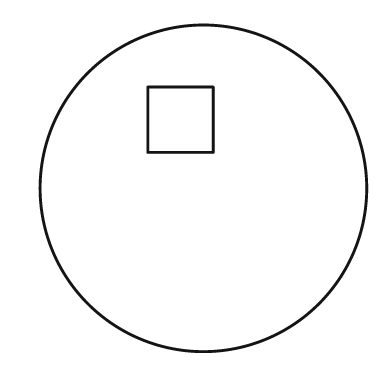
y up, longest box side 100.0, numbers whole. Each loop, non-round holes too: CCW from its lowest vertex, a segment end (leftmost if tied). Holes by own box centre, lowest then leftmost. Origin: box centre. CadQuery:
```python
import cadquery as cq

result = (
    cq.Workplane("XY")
    .moveTo(0.0, 0.0)
    .circle(50.0)
    .moveTo(-17.0, 11.0)
    .lineTo(3.0, 11.0)
    .lineTo(3.0, 31.0)
    .lineTo(-17.0, 31.0)
    .close()
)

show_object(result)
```